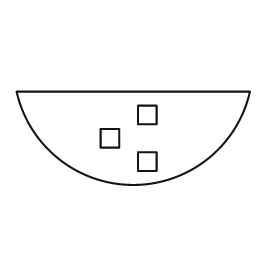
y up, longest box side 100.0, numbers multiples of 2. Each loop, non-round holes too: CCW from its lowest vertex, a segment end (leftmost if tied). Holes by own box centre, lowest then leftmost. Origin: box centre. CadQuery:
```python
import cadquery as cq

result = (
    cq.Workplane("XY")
    .moveTo(-50.0, 20.0)
    .threePointArc((0.0, -20.0), (50.0, 20.0))
    .close()
    .moveTo(2.0, -14.0)
    .lineTo(10.0, -14.0)
    .lineTo(10.0, -6.0)
    .lineTo(2.0, -6.0)
    .close()
    .moveTo(-14.0, -4.0)
    .lineTo(-6.0, -4.0)
    .lineTo(-6.0, 4.0)
    .lineTo(-14.0, 4.0)
    .close()
    .moveTo(2.0, 6.0)
    .lineTo(10.0, 6.0)
    .lineTo(10.0, 14.0)
    .lineTo(2.0, 14.0)
    .close()
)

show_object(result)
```